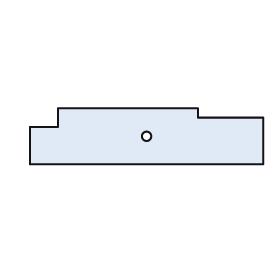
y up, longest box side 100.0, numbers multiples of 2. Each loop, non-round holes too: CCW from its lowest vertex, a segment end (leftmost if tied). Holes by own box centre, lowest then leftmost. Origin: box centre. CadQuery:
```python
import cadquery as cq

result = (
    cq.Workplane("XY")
    .moveTo(-50.0, -12.0)
    .lineTo(50.0, -12.0)
    .lineTo(50.0, 8.0)
    .lineTo(22.0, 8.0)
    .lineTo(22.0, 12.0)
    .lineTo(-38.0, 12.0)
    .lineTo(-38.0, 4.0)
    .lineTo(-50.0, 4.0)
    .close()
    .moveTo(0.0, 0.0)
    .circle(2.0)
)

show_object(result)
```